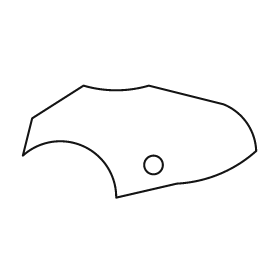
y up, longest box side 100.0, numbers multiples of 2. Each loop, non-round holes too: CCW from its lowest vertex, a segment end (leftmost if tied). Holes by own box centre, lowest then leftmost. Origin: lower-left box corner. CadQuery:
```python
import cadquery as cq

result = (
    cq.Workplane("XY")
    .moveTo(40.0, 0.0)
    .lineTo(66.0, 6.0)
    .threePointArc((84.0, 10.0), (100.0, 20.0))
    .threePointArc((96.0, 32.0), (86.0, 40.0))
    .lineTo(54.0, 48.0)
    .threePointArc((40.0, 46.0), (26.0, 48.0))
    .lineTo(4.0, 34.0)
    .lineTo(0.0, 18.0)
    .threePointArc((26.0, 22.0), (40.0, 0.0))
    .close()
    .moveTo(56.0, 14.0)
    .circle(4.0)
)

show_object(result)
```